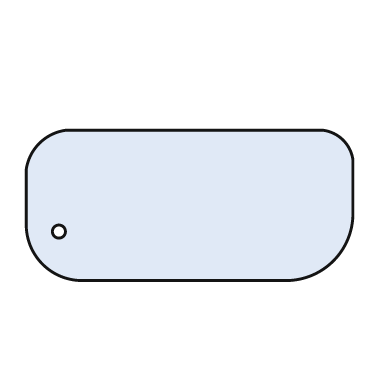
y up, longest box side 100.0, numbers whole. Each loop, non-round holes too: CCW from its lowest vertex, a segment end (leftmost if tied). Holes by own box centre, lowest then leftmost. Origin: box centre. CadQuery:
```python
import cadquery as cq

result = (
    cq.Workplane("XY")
    .moveTo(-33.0, -23.0)
    .lineTo(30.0, -23.0)
    .threePointArc((44.0, -17.0), (50.0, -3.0))
    .lineTo(50.0, 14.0)
    .threePointArc((47.0, 20.0), (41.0, 23.0))
    .lineTo(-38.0, 23.0)
    .threePointArc((-46.0, 19.0), (-50.0, 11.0))
    .lineTo(-50.0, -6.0)
    .threePointArc((-45.0, -18.0), (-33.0, -23.0))
    .close()
    .moveTo(-40.0, -8.0)
    .circle(2.0)
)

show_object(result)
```